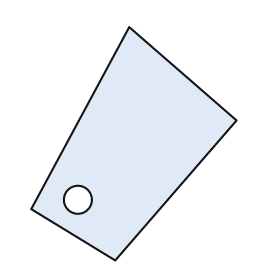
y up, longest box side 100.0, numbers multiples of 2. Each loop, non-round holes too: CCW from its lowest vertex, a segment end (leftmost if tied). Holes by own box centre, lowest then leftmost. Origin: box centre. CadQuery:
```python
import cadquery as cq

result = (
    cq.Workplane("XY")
    .moveTo(-8.0, -50.0)
    .lineTo(44.0, 10.0)
    .lineTo(-2.0, 50.0)
    .lineTo(-44.0, -28.0)
    .close()
    .moveTo(-24.0, -24.0)
    .circle(6.0)
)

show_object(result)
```